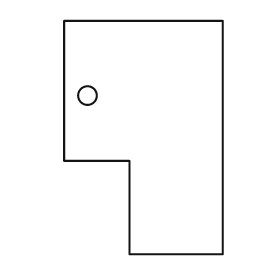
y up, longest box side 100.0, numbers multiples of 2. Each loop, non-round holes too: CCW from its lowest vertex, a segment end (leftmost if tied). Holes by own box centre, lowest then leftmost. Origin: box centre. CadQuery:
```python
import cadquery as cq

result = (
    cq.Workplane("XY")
    .moveTo(-6.0, -50.0)
    .lineTo(34.0, -50.0)
    .lineTo(34.0, 50.0)
    .lineTo(-34.0, 50.0)
    .lineTo(-34.0, -10.0)
    .lineTo(-6.0, -10.0)
    .close()
    .moveTo(-24.0, 18.0)
    .circle(4.0)
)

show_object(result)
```